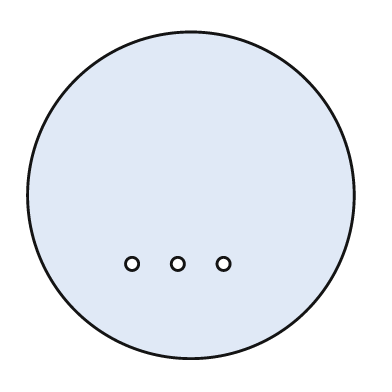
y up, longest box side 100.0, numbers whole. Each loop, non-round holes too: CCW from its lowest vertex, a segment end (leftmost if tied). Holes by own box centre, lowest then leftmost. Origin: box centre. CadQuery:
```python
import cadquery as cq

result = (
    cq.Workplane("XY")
    .moveTo(0.0, 0.0)
    .circle(50.0)
    .moveTo(-18.0, -21.0)
    .circle(2.0)
    .moveTo(-4.0, -21.0)
    .circle(2.0)
    .moveTo(10.0, -21.0)
    .circle(2.0)
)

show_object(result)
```